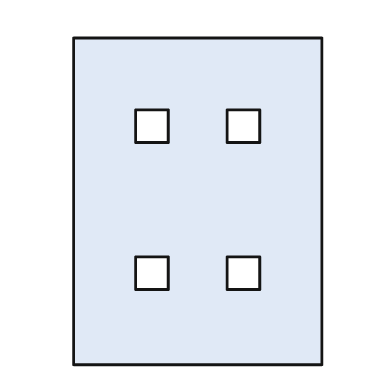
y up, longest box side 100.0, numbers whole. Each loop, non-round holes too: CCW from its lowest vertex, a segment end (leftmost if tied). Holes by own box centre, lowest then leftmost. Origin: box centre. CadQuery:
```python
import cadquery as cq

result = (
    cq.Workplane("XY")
    .moveTo(-38.0, -50.0)
    .lineTo(38.0, -50.0)
    .lineTo(38.0, 50.0)
    .lineTo(-38.0, 50.0)
    .close()
    .moveTo(-19.0, -27.0)
    .lineTo(-9.0, -27.0)
    .lineTo(-9.0, -17.0)
    .lineTo(-19.0, -17.0)
    .close()
    .moveTo(9.0, -27.0)
    .lineTo(19.0, -27.0)
    .lineTo(19.0, -17.0)
    .lineTo(9.0, -17.0)
    .close()
    .moveTo(-19.0, 18.0)
    .lineTo(-9.0, 18.0)
    .lineTo(-9.0, 28.0)
    .lineTo(-19.0, 28.0)
    .close()
    .moveTo(9.0, 18.0)
    .lineTo(19.0, 18.0)
    .lineTo(19.0, 28.0)
    .lineTo(9.0, 28.0)
    .close()
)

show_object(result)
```